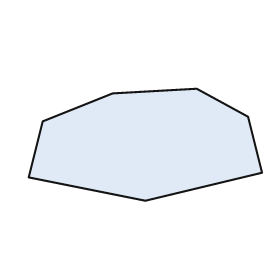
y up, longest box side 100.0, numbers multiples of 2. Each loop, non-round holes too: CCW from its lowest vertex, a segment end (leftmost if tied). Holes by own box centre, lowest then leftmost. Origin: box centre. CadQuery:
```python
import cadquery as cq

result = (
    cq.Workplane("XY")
    .moveTo(0.0, -24.0)
    .lineTo(50.0, -12.0)
    .lineTo(44.0, 12.0)
    .lineTo(22.0, 24.0)
    .lineTo(-14.0, 22.0)
    .lineTo(-44.0, 10.0)
    .lineTo(-50.0, -14.0)
    .close()
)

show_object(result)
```